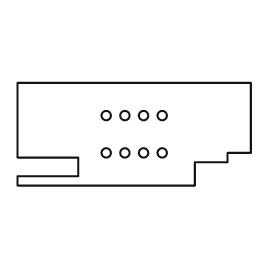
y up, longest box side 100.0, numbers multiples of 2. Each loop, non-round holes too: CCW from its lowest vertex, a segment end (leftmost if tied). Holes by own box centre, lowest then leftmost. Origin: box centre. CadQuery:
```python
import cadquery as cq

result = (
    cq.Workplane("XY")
    .moveTo(-50.0, -22.0)
    .lineTo(26.0, -22.0)
    .lineTo(26.0, -12.0)
    .lineTo(40.0, -12.0)
    .lineTo(40.0, -8.0)
    .lineTo(50.0, -8.0)
    .lineTo(50.0, 22.0)
    .lineTo(-50.0, 22.0)
    .lineTo(-50.0, -10.0)
    .lineTo(-24.0, -10.0)
    .lineTo(-24.0, -18.0)
    .lineTo(-50.0, -18.0)
    .close()
    .moveTo(-12.0, -8.0)
    .circle(2.0)
    .moveTo(-4.0, -8.0)
    .circle(2.0)
    .moveTo(4.0, -8.0)
    .circle(2.0)
    .moveTo(12.0, -8.0)
    .circle(2.0)
    .moveTo(-12.0, 8.0)
    .circle(2.0)
    .moveTo(-4.0, 8.0)
    .circle(2.0)
    .moveTo(4.0, 8.0)
    .circle(2.0)
    .moveTo(12.0, 8.0)
    .circle(2.0)
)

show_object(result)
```